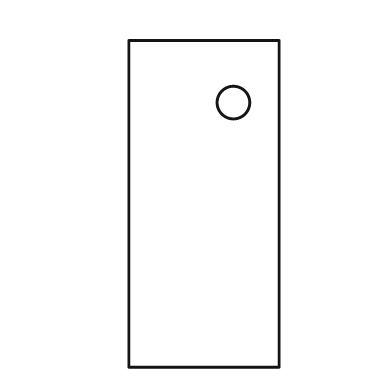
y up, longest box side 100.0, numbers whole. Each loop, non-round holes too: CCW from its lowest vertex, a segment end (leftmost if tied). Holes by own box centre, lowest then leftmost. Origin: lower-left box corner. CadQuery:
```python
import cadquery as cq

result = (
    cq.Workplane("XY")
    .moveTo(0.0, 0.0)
    .lineTo(46.0, 0.0)
    .lineTo(46.0, 100.0)
    .lineTo(0.0, 100.0)
    .close()
    .moveTo(32.0, 81.0)
    .circle(5.0)
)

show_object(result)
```